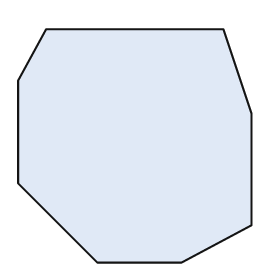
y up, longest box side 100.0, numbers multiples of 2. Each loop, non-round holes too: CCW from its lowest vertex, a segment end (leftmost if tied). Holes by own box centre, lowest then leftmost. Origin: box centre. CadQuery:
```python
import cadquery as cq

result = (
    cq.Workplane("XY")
    .moveTo(-16.0, -50.0)
    .lineTo(20.0, -50.0)
    .lineTo(50.0, -34.0)
    .lineTo(50.0, 14.0)
    .lineTo(38.0, 50.0)
    .lineTo(-38.0, 50.0)
    .lineTo(-50.0, 28.0)
    .lineTo(-50.0, -16.0)
    .close()
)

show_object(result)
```